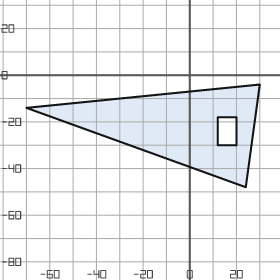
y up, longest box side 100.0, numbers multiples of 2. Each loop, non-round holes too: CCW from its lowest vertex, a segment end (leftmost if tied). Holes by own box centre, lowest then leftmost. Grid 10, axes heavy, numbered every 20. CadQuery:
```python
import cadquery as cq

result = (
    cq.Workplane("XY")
    .moveTo(24.0, -48.0)
    .lineTo(30.0, -4.0)
    .lineTo(-70.0, -14.0)
    .close()
    .moveTo(12.0, -30.0)
    .lineTo(20.0, -30.0)
    .lineTo(20.0, -18.0)
    .lineTo(12.0, -18.0)
    .close()
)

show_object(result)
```